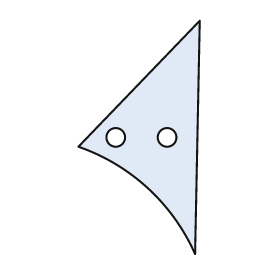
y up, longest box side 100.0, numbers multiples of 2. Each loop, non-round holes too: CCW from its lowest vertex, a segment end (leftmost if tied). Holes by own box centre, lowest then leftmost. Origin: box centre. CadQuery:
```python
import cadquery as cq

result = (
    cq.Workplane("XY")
    .moveTo(24.0, -50.0)
    .lineTo(26.0, 50.0)
    .lineTo(-26.0, -4.0)
    .threePointArc((4.0, -22.0), (24.0, -50.0))
    .close()
    .moveTo(-10.0, 0.0)
    .circle(4.0)
    .moveTo(12.0, 0.0)
    .circle(4.0)
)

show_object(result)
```